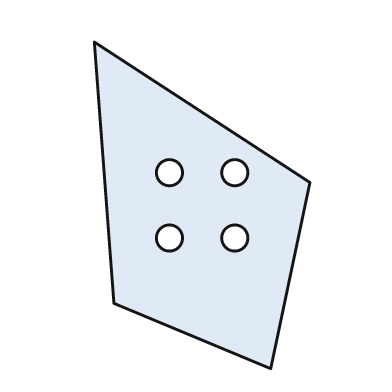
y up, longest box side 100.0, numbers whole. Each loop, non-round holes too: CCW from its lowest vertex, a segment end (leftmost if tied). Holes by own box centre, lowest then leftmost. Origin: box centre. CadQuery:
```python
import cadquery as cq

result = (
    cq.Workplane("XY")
    .moveTo(21.0, -50.0)
    .lineTo(33.0, 7.0)
    .lineTo(-33.0, 50.0)
    .lineTo(-27.0, -30.0)
    .close()
    .moveTo(-10.0, -10.0)
    .circle(4.0)
    .moveTo(10.0, -10.0)
    .circle(4.0)
    .moveTo(-10.0, 10.0)
    .circle(4.0)
    .moveTo(10.0, 10.0)
    .circle(4.0)
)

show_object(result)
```